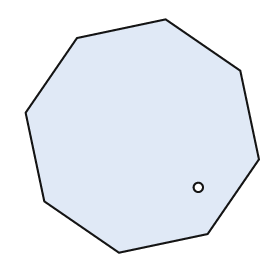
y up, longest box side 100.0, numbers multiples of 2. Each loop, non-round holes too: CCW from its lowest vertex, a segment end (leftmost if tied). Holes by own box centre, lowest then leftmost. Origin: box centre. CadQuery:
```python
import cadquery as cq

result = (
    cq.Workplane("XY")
    .moveTo(-10.0, -50.0)
    .lineTo(28.0, -42.0)
    .lineTo(50.0, -10.0)
    .lineTo(42.0, 28.0)
    .lineTo(10.0, 50.0)
    .lineTo(-28.0, 42.0)
    .lineTo(-50.0, 10.0)
    .lineTo(-42.0, -28.0)
    .close()
    .moveTo(24.0, -22.0)
    .circle(2.0)
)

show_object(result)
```